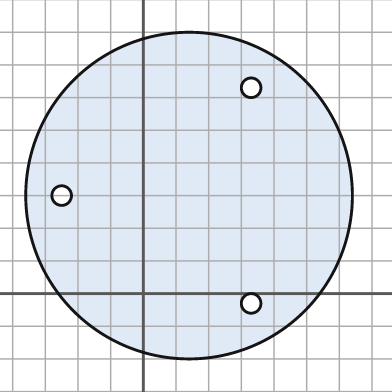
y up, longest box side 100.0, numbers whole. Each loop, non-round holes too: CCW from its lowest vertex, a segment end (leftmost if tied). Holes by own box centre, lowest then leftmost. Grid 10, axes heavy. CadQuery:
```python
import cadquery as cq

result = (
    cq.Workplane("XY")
    .moveTo(14.0, 30.0)
    .circle(50.0)
    .moveTo(33.0, -3.0)
    .circle(3.0)
    .moveTo(-25.0, 30.0)
    .circle(3.0)
    .moveTo(33.0, 63.0)
    .circle(3.0)
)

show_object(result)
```